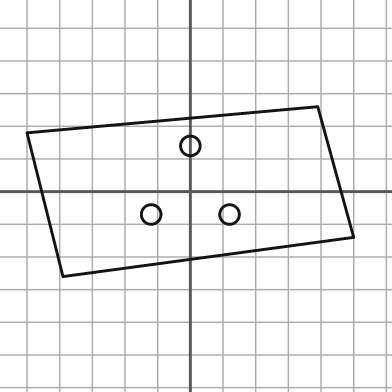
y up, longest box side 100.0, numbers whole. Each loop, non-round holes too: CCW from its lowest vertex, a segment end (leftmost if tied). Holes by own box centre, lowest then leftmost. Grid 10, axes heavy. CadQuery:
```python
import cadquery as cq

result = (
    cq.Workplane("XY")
    .moveTo(-39.0, -26.0)
    .lineTo(50.0, -14.0)
    .lineTo(39.0, 26.0)
    .lineTo(-50.0, 18.0)
    .close()
    .moveTo(-12.0, -7.0)
    .circle(3.0)
    .moveTo(12.0, -7.0)
    .circle(3.0)
    .moveTo(0.0, 14.0)
    .circle(3.0)
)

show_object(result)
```